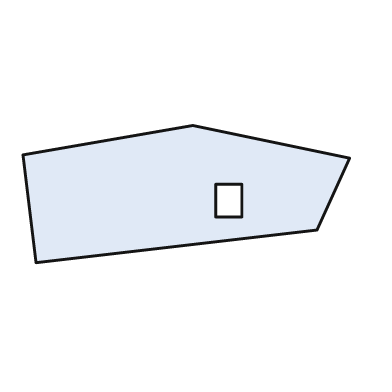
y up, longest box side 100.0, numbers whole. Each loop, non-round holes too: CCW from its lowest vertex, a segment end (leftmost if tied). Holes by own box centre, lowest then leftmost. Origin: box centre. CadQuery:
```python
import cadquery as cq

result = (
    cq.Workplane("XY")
    .moveTo(-46.0, -21.0)
    .lineTo(40.0, -11.0)
    .lineTo(50.0, 11.0)
    .lineTo(2.0, 21.0)
    .lineTo(-50.0, 12.0)
    .close()
    .moveTo(9.0, -7.0)
    .lineTo(17.0, -7.0)
    .lineTo(17.0, 3.0)
    .lineTo(9.0, 3.0)
    .close()
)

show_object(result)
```